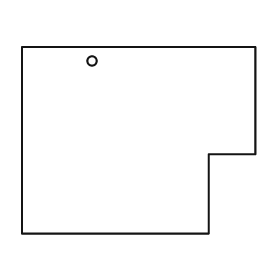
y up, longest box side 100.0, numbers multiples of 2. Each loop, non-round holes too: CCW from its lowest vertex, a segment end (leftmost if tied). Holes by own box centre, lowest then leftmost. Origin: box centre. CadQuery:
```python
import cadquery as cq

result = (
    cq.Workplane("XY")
    .moveTo(-50.0, -40.0)
    .lineTo(30.0, -40.0)
    .lineTo(30.0, -6.0)
    .lineTo(50.0, -6.0)
    .lineTo(50.0, 40.0)
    .lineTo(-50.0, 40.0)
    .close()
    .moveTo(-20.0, 34.0)
    .circle(2.0)
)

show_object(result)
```